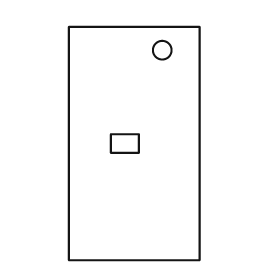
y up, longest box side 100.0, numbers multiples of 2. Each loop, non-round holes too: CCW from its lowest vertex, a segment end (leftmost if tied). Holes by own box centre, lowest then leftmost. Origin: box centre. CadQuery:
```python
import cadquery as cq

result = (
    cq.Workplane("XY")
    .moveTo(-28.0, -50.0)
    .lineTo(28.0, -50.0)
    .lineTo(28.0, 50.0)
    .lineTo(-28.0, 50.0)
    .close()
    .moveTo(-10.0, -4.0)
    .lineTo(2.0, -4.0)
    .lineTo(2.0, 4.0)
    .lineTo(-10.0, 4.0)
    .close()
    .moveTo(12.0, 40.0)
    .circle(4.0)
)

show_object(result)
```